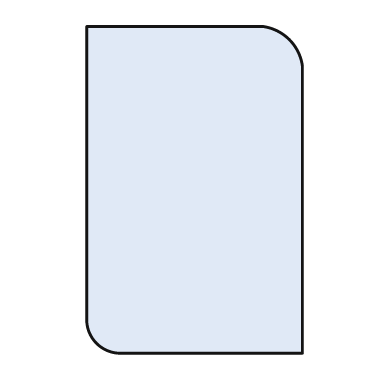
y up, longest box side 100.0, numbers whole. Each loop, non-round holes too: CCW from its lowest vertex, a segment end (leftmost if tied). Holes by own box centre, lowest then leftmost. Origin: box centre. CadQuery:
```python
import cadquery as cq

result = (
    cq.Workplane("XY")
    .moveTo(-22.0, -50.0)
    .lineTo(33.0, -50.0)
    .lineTo(33.0, 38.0)
    .threePointArc((29.0, 46.0), (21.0, 50.0))
    .lineTo(-33.0, 50.0)
    .lineTo(-33.0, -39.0)
    .threePointArc((-30.0, -47.0), (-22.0, -50.0))
    .close()
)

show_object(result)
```